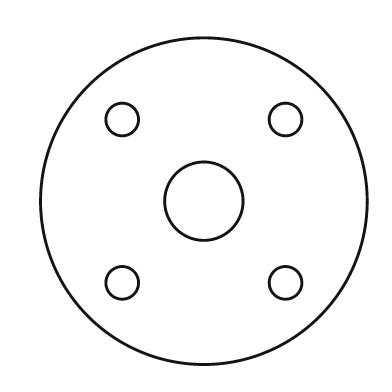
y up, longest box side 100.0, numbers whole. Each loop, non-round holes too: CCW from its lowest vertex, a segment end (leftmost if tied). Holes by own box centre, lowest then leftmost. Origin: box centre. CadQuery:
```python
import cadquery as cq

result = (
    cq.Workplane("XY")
    .moveTo(0.0, 0.0)
    .circle(50.0)
    .moveTo(-25.0, -25.0)
    .circle(5.0)
    .moveTo(25.0, -25.0)
    .circle(5.0)
    .moveTo(0.0, 0.0)
    .circle(12.0)
    .moveTo(-25.0, 25.0)
    .circle(5.0)
    .moveTo(25.0, 25.0)
    .circle(5.0)
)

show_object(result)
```